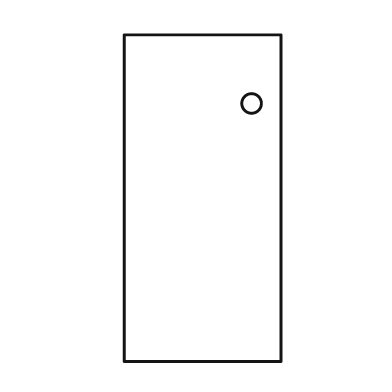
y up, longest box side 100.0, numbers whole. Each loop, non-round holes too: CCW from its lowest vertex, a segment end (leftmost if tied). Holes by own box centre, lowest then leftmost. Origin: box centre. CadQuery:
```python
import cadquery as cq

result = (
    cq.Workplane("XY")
    .moveTo(-24.0, -50.0)
    .lineTo(24.0, -50.0)
    .lineTo(24.0, 50.0)
    .lineTo(-24.0, 50.0)
    .close()
    .moveTo(15.0, 29.0)
    .circle(3.0)
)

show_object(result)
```